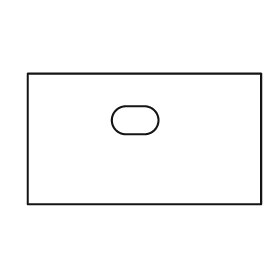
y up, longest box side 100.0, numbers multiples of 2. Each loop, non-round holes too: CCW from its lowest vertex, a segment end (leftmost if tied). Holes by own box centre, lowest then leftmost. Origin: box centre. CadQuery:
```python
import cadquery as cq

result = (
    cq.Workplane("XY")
    .moveTo(-50.0, -28.0)
    .lineTo(50.0, -28.0)
    .lineTo(50.0, 28.0)
    .lineTo(-50.0, 28.0)
    .close()
    .moveTo(-8.0, 2.0)
    .lineTo(0.0, 2.0)
    .threePointArc((6.0, 8.0), (0.0, 14.0))
    .lineTo(-8.0, 14.0)
    .threePointArc((-14.0, 8.0), (-8.0, 2.0))
    .close()
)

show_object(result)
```